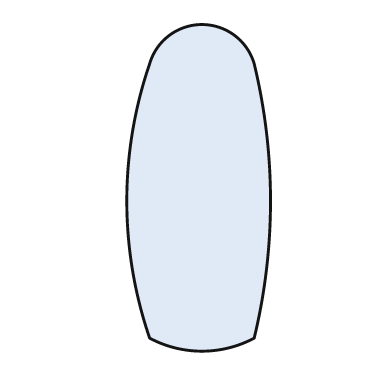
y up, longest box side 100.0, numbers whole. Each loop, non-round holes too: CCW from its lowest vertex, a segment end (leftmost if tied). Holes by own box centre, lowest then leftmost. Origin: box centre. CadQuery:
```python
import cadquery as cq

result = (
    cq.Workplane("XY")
    .moveTo(-15.0, -46.0)
    .threePointArc((1.0, -50.0), (17.0, -46.0))
    .threePointArc((22.0, -4.0), (17.0, 38.0))
    .threePointArc((1.0, 50.0), (-15.0, 38.0))
    .threePointArc((-22.0, -4.0), (-15.0, -46.0))
    .close()
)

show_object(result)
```